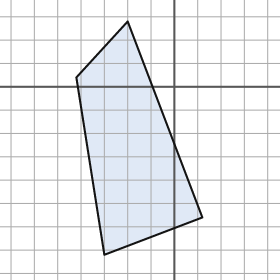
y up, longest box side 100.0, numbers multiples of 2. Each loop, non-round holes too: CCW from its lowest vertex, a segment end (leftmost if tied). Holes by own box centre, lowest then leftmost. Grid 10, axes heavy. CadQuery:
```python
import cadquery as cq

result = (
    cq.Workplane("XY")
    .moveTo(-30.0, -72.0)
    .lineTo(12.0, -56.0)
    .lineTo(-20.0, 28.0)
    .lineTo(-42.0, 4.0)
    .close()
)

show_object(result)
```